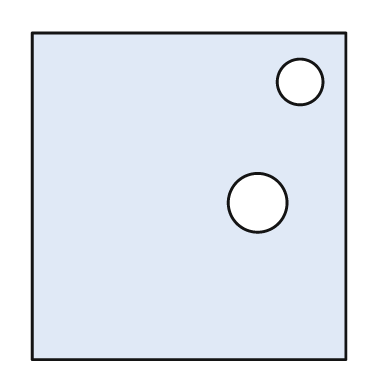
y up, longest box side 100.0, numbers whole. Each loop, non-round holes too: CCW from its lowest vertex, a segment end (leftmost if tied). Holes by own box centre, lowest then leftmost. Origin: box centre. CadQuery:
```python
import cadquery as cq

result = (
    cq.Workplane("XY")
    .moveTo(-48.0, -50.0)
    .lineTo(48.0, -50.0)
    .lineTo(48.0, 50.0)
    .lineTo(-48.0, 50.0)
    .close()
    .moveTo(21.0, -2.0)
    .circle(9.0)
    .moveTo(34.0, 35.0)
    .circle(7.0)
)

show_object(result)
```